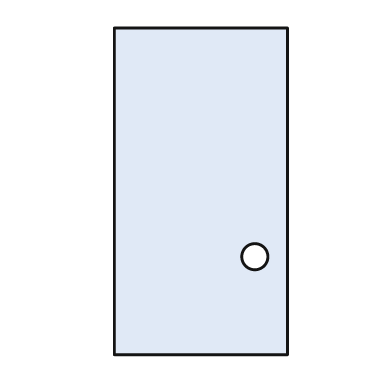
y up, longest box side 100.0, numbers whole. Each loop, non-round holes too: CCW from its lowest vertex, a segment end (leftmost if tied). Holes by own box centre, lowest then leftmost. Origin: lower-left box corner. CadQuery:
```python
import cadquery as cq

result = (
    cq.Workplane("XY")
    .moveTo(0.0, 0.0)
    .lineTo(53.0, 0.0)
    .lineTo(53.0, 100.0)
    .lineTo(0.0, 100.0)
    .close()
    .moveTo(43.0, 30.0)
    .circle(4.0)
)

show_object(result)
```